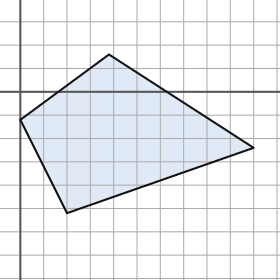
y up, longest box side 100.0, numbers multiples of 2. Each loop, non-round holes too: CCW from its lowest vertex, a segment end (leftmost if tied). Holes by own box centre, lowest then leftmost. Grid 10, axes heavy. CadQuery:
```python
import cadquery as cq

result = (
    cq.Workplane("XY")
    .moveTo(20.0, -52.0)
    .lineTo(100.0, -24.0)
    .lineTo(38.0, 16.0)
    .lineTo(0.0, -12.0)
    .close()
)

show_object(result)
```